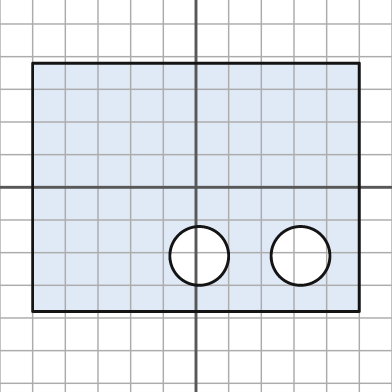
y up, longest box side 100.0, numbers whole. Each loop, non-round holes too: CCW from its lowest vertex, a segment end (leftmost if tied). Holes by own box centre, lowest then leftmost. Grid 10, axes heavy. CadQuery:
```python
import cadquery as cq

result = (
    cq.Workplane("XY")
    .moveTo(-50.0, -38.0)
    .lineTo(50.0, -38.0)
    .lineTo(50.0, 38.0)
    .lineTo(-50.0, 38.0)
    .close()
    .moveTo(1.0, -21.0)
    .circle(9.0)
    .moveTo(32.0, -21.0)
    .circle(9.0)
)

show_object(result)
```